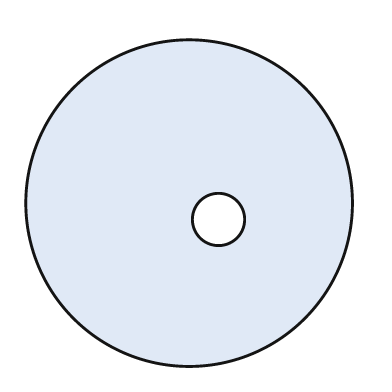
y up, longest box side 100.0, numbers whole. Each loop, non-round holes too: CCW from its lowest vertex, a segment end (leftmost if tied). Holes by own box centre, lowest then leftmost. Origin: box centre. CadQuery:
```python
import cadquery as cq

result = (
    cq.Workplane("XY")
    .moveTo(0.0, 0.0)
    .circle(50.0)
    .moveTo(9.0, -5.0)
    .circle(8.0)
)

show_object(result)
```